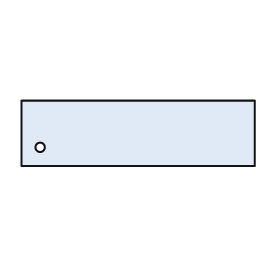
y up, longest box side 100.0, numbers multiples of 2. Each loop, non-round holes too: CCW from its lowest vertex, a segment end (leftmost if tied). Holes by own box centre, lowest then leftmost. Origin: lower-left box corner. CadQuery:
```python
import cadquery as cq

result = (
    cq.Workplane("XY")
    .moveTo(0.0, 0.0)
    .lineTo(100.0, 0.0)
    .lineTo(100.0, 28.0)
    .lineTo(0.0, 28.0)
    .close()
    .moveTo(8.0, 8.0)
    .circle(2.0)
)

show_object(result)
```